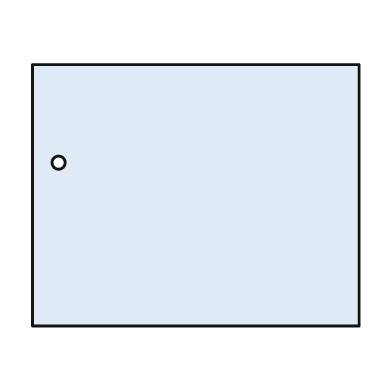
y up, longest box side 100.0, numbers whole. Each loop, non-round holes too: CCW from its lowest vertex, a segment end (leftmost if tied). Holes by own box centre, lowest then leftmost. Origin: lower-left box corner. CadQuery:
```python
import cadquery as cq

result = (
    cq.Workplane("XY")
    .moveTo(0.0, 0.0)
    .lineTo(100.0, 0.0)
    .lineTo(100.0, 80.0)
    .lineTo(0.0, 80.0)
    .close()
    .moveTo(8.0, 50.0)
    .circle(2.0)
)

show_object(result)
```